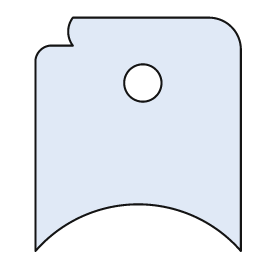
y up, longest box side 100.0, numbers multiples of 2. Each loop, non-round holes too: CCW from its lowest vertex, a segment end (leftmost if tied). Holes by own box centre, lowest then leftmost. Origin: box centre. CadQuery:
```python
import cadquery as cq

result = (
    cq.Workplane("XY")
    .moveTo(-44.0, -50.0)
    .threePointArc((0.0, -30.0), (44.0, -50.0))
    .lineTo(44.0, 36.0)
    .threePointArc((40.0, 46.0), (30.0, 50.0))
    .lineTo(-28.0, 50.0)
    .threePointArc((-30.0, 44.0), (-28.0, 38.0))
    .lineTo(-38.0, 38.0)
    .threePointArc((-42.0, 36.0), (-44.0, 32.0))
    .close()
    .moveTo(2.0, 22.0)
    .circle(8.0)
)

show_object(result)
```